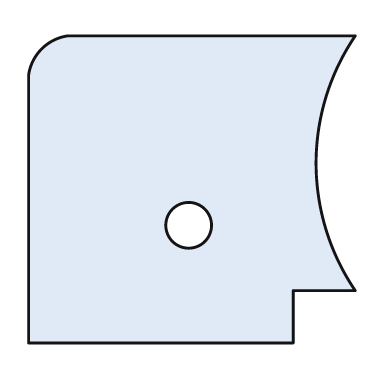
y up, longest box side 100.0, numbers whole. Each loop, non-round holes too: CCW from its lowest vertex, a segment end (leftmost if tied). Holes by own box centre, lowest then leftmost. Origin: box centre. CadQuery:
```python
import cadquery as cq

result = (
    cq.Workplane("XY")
    .moveTo(-50.0, -47.0)
    .lineTo(31.0, -47.0)
    .lineTo(31.0, -31.0)
    .lineTo(50.0, -31.0)
    .threePointArc((38.0, 8.0), (50.0, 47.0))
    .lineTo(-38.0, 47.0)
    .threePointArc((-46.0, 43.0), (-50.0, 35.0))
    .close()
    .moveTo(-1.0, -11.0)
    .circle(7.0)
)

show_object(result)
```